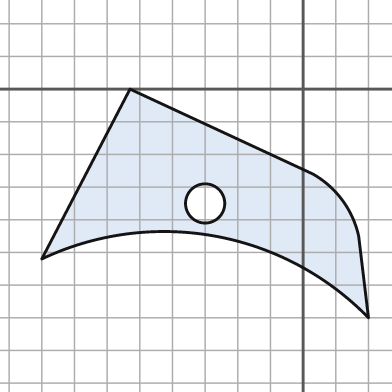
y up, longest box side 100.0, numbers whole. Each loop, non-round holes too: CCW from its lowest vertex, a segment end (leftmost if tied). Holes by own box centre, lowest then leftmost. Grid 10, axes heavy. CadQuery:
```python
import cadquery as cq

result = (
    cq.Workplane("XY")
    .moveTo(20.0, -70.0)
    .lineTo(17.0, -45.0)
    .threePointArc((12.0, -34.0), (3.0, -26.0))
    .lineTo(-53.0, 0.0)
    .lineTo(-80.0, -52.0)
    .threePointArc((-27.0, -45.0), (20.0, -70.0))
    .close()
    .moveTo(-30.0, -35.0)
    .circle(6.0)
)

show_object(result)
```